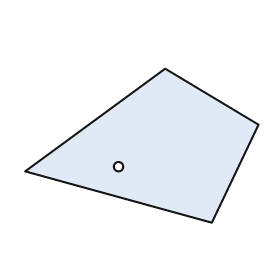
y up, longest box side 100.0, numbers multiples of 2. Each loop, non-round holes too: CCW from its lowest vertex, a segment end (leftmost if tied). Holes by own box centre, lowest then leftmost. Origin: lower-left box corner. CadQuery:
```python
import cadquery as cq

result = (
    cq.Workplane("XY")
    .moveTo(80.0, 0.0)
    .lineTo(100.0, 42.0)
    .lineTo(60.0, 66.0)
    .lineTo(0.0, 22.0)
    .close()
    .moveTo(40.0, 24.0)
    .circle(2.0)
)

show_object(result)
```